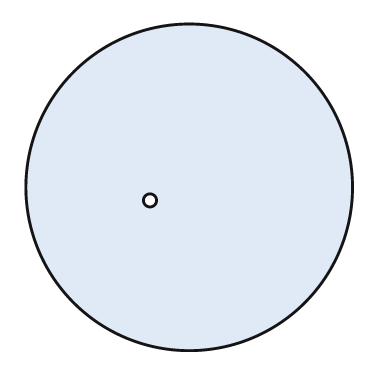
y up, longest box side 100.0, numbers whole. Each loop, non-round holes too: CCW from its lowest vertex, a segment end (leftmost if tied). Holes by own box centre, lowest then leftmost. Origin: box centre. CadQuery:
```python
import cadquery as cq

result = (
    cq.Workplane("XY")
    .moveTo(0.0, 0.0)
    .circle(50.0)
    .moveTo(-12.0, -4.0)
    .circle(2.0)
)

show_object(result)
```